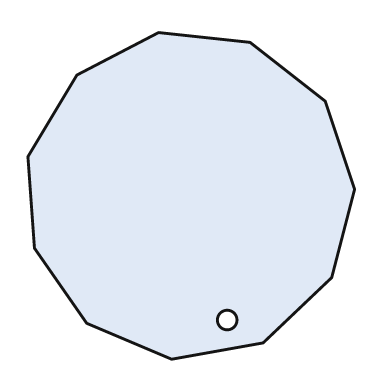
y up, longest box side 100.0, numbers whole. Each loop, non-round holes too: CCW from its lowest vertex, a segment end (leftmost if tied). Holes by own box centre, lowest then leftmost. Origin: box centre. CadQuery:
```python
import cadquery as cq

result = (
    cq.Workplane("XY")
    .moveTo(-6.0, -50.0)
    .lineTo(22.0, -45.0)
    .lineTo(43.0, -25.0)
    .lineTo(50.0, 2.0)
    .lineTo(41.0, 29.0)
    .lineTo(18.0, 47.0)
    .lineTo(-10.0, 50.0)
    .lineTo(-35.0, 37.0)
    .lineTo(-50.0, 12.0)
    .lineTo(-48.0, -16.0)
    .lineTo(-32.0, -39.0)
    .close()
    .moveTo(11.0, -38.0)
    .circle(3.0)
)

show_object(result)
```